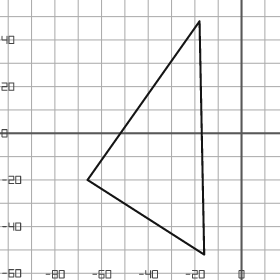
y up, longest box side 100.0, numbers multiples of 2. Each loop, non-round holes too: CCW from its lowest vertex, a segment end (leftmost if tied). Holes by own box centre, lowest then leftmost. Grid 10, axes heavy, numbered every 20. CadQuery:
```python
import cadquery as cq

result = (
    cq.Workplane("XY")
    .moveTo(-16.0, -52.0)
    .lineTo(-18.0, 48.0)
    .lineTo(-66.0, -20.0)
    .close()
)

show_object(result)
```